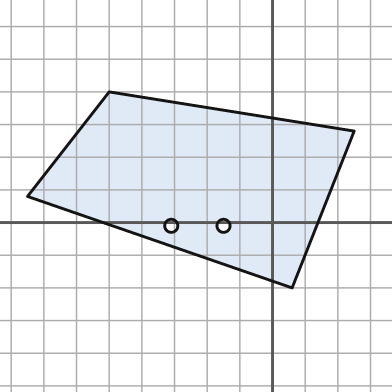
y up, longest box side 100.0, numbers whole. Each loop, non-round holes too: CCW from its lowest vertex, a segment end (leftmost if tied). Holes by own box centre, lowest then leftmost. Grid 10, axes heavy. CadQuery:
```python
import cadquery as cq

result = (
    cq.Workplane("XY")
    .moveTo(6.0, -20.0)
    .lineTo(25.0, 28.0)
    .lineTo(-50.0, 40.0)
    .lineTo(-75.0, 8.0)
    .close()
    .moveTo(-31.0, -1.0)
    .circle(2.0)
    .moveTo(-15.0, -1.0)
    .circle(2.0)
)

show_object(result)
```